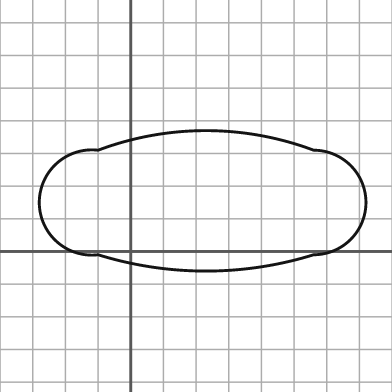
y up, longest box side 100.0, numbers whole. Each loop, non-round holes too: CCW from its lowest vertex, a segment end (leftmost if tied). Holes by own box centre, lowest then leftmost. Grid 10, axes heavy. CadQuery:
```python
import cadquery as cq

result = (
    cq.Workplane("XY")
    .moveTo(-10.0, -1.0)
    .threePointArc((23.0, -6.0), (56.0, -1.0))
    .threePointArc((72.0, 15.0), (56.0, 31.0))
    .threePointArc((23.0, 37.0), (-10.0, 31.0))
    .threePointArc((-28.0, 15.0), (-10.0, -1.0))
    .close()
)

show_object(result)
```